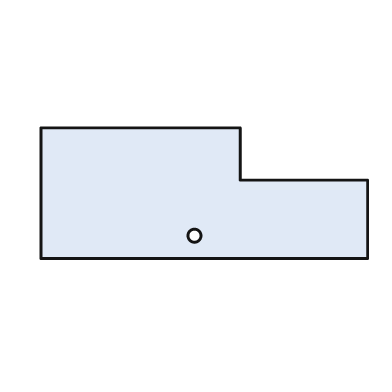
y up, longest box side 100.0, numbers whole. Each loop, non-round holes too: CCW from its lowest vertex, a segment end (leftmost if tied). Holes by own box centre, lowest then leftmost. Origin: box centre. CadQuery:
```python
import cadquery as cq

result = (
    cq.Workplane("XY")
    .moveTo(-50.0, -20.0)
    .lineTo(50.0, -20.0)
    .lineTo(50.0, 4.0)
    .lineTo(11.0, 4.0)
    .lineTo(11.0, 20.0)
    .lineTo(-50.0, 20.0)
    .close()
    .moveTo(-3.0, -13.0)
    .circle(2.0)
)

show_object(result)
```